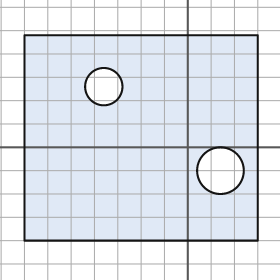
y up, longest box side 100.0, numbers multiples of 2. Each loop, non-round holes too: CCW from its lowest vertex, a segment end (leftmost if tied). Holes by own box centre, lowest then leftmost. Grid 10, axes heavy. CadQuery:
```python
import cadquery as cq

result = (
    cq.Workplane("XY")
    .moveTo(-70.0, -40.0)
    .lineTo(30.0, -40.0)
    .lineTo(30.0, 48.0)
    .lineTo(-70.0, 48.0)
    .close()
    .moveTo(14.0, -10.0)
    .circle(10.0)
    .moveTo(-36.0, 26.0)
    .circle(8.0)
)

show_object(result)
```